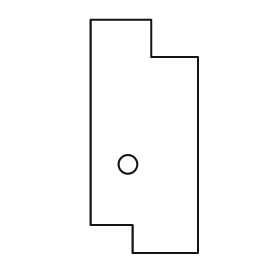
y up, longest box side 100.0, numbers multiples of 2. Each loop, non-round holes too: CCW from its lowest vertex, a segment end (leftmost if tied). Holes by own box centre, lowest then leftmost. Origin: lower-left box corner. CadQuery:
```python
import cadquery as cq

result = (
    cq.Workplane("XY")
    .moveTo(18.0, 0.0)
    .lineTo(46.0, 0.0)
    .lineTo(46.0, 84.0)
    .lineTo(26.0, 84.0)
    .lineTo(26.0, 100.0)
    .lineTo(0.0, 100.0)
    .lineTo(0.0, 12.0)
    .lineTo(18.0, 12.0)
    .close()
    .moveTo(16.0, 38.0)
    .circle(4.0)
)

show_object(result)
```